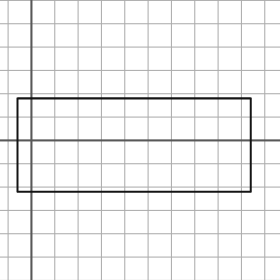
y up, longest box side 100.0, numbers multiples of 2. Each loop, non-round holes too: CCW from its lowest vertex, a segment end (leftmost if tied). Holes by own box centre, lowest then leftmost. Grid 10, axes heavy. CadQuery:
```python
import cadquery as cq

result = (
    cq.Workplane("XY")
    .moveTo(-6.0, -22.0)
    .lineTo(94.0, -22.0)
    .lineTo(94.0, 18.0)
    .lineTo(-6.0, 18.0)
    .close()
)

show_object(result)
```